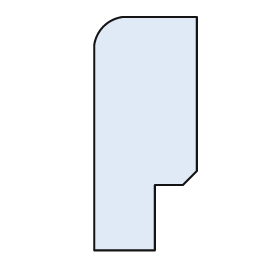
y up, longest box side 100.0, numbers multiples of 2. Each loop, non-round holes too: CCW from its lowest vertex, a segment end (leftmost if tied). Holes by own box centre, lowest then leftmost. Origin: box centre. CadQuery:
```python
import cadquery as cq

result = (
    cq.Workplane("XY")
    .moveTo(-22.0, -50.0)
    .lineTo(4.0, -50.0)
    .lineTo(4.0, -22.0)
    .lineTo(16.0, -22.0)
    .lineTo(22.0, -16.0)
    .lineTo(22.0, 50.0)
    .lineTo(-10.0, 50.0)
    .threePointArc((-18.0, 46.0), (-22.0, 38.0))
    .close()
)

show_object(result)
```